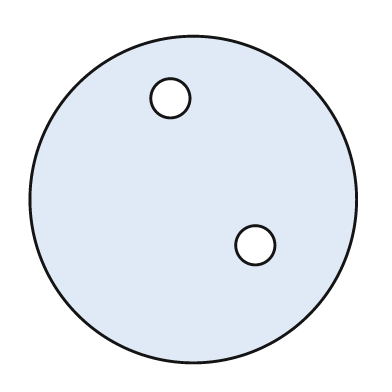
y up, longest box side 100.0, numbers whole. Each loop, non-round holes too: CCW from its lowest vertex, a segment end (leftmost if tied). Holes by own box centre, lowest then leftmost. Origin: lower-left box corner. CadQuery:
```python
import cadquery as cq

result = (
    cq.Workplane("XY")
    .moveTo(50.0, 50.0)
    .circle(50.0)
    .moveTo(69.0, 36.0)
    .circle(6.0)
    .moveTo(43.0, 81.0)
    .circle(6.0)
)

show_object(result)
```